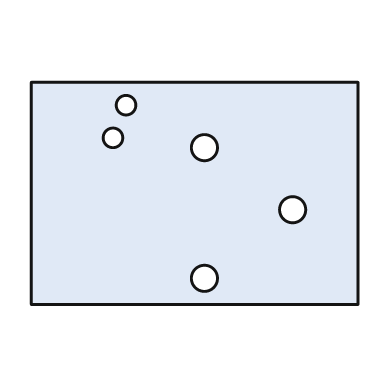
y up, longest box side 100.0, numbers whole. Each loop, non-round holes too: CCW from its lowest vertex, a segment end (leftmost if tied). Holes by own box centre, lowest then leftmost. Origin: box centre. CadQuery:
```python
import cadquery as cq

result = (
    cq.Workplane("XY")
    .moveTo(-50.0, -34.0)
    .lineTo(50.0, -34.0)
    .lineTo(50.0, 34.0)
    .lineTo(-50.0, 34.0)
    .close()
    .moveTo(3.0, -26.0)
    .circle(4.0)
    .moveTo(30.0, -5.0)
    .circle(4.0)
    .moveTo(3.0, 14.0)
    .circle(4.0)
    .moveTo(-25.0, 17.0)
    .circle(3.0)
    .moveTo(-21.0, 27.0)
    .circle(3.0)
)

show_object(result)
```